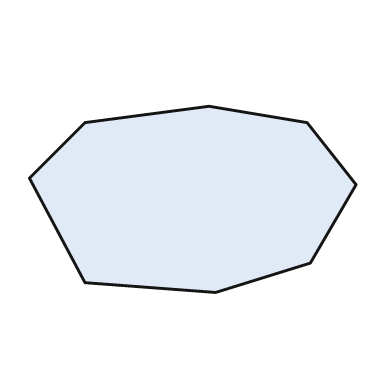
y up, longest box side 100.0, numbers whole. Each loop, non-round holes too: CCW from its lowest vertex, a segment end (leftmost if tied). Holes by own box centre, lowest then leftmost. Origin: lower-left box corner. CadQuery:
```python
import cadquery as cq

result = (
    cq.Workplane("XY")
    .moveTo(57.0, 0.0)
    .lineTo(86.0, 9.0)
    .lineTo(100.0, 33.0)
    .lineTo(85.0, 52.0)
    .lineTo(55.0, 57.0)
    .lineTo(17.0, 52.0)
    .lineTo(0.0, 35.0)
    .lineTo(17.0, 3.0)
    .close()
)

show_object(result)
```